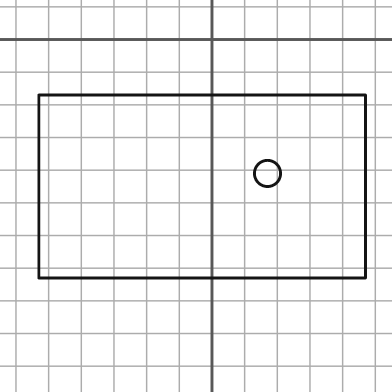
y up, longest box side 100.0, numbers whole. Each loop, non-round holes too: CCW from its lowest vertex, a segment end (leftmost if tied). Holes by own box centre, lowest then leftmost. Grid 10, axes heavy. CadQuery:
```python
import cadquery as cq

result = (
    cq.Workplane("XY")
    .moveTo(-53.0, -73.0)
    .lineTo(47.0, -73.0)
    .lineTo(47.0, -17.0)
    .lineTo(-53.0, -17.0)
    .close()
    .moveTo(17.0, -41.0)
    .circle(4.0)
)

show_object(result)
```